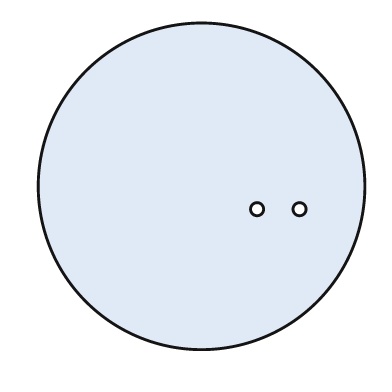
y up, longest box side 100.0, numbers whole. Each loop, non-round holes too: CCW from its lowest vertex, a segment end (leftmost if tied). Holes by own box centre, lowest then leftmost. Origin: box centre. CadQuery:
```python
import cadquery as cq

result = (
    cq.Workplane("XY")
    .moveTo(0.0, 0.0)
    .circle(50.0)
    .moveTo(17.0, -7.0)
    .circle(2.0)
    .moveTo(30.0, -7.0)
    .circle(2.0)
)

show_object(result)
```